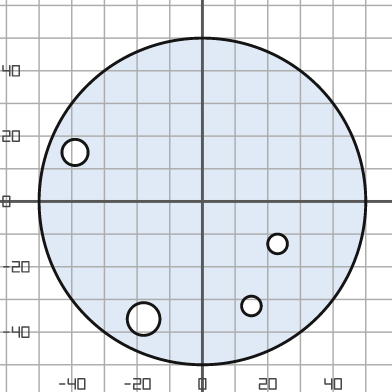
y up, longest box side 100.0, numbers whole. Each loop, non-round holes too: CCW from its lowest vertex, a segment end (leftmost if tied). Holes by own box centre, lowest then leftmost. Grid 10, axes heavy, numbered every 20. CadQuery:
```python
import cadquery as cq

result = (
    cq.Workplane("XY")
    .moveTo(0.0, 0.0)
    .circle(50.0)
    .moveTo(-18.0, -36.0)
    .circle(5.0)
    .moveTo(15.0, -32.0)
    .circle(3.0)
    .moveTo(23.0, -13.0)
    .circle(3.0)
    .moveTo(-39.0, 15.0)
    .circle(4.0)
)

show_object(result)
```